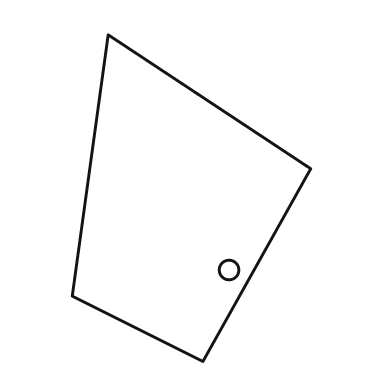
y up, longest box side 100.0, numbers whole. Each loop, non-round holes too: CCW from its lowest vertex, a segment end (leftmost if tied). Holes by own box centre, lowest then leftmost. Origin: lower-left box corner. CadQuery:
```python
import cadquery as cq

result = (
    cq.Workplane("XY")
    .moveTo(40.0, 0.0)
    .lineTo(73.0, 59.0)
    .lineTo(11.0, 100.0)
    .lineTo(0.0, 20.0)
    .close()
    .moveTo(48.0, 28.0)
    .circle(3.0)
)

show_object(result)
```